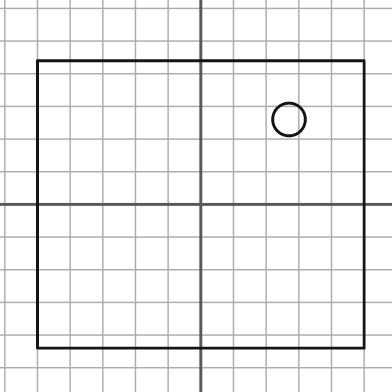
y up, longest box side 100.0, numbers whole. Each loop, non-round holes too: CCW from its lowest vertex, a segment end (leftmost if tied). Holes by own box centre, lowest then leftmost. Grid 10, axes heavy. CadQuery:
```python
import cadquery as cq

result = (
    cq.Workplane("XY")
    .moveTo(-50.0, -44.0)
    .lineTo(50.0, -44.0)
    .lineTo(50.0, 44.0)
    .lineTo(-50.0, 44.0)
    .close()
    .moveTo(27.0, 26.0)
    .circle(5.0)
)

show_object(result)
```